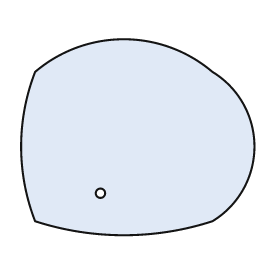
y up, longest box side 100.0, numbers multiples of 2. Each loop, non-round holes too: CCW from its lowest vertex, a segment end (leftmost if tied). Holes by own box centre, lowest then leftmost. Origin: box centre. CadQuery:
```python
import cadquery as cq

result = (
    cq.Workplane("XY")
    .moveTo(-44.0, -36.0)
    .threePointArc((-6.0, -42.0), (32.0, -36.0))
    .threePointArc((50.0, -4.0), (32.0, 28.0))
    .threePointArc((-6.0, 42.0), (-44.0, 28.0))
    .threePointArc((-50.0, -4.0), (-44.0, -36.0))
    .close()
    .moveTo(-16.0, -24.0)
    .circle(2.0)
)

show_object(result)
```